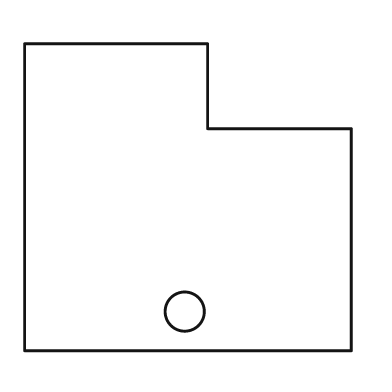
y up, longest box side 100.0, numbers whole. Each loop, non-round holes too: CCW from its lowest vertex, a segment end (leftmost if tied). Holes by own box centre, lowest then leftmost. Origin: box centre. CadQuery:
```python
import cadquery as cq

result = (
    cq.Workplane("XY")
    .moveTo(-50.0, -47.0)
    .lineTo(50.0, -47.0)
    .lineTo(50.0, 21.0)
    .lineTo(6.0, 21.0)
    .lineTo(6.0, 47.0)
    .lineTo(-50.0, 47.0)
    .close()
    .moveTo(-1.0, -35.0)
    .circle(6.0)
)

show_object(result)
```